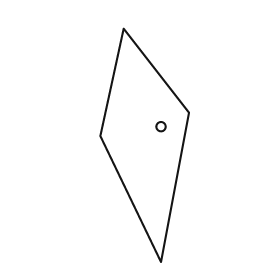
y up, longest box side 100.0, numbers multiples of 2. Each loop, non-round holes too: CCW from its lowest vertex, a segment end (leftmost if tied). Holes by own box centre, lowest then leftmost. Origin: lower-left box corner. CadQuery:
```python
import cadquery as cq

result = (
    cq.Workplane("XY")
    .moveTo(26.0, 0.0)
    .lineTo(38.0, 64.0)
    .lineTo(10.0, 100.0)
    .lineTo(0.0, 54.0)
    .close()
    .moveTo(26.0, 58.0)
    .circle(2.0)
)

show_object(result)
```